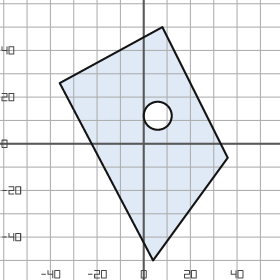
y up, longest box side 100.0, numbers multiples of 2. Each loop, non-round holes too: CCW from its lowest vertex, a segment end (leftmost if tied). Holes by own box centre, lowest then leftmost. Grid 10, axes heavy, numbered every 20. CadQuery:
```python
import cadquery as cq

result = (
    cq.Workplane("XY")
    .moveTo(4.0, -50.0)
    .lineTo(36.0, -6.0)
    .lineTo(8.0, 50.0)
    .lineTo(-36.0, 26.0)
    .close()
    .moveTo(6.0, 12.0)
    .circle(6.0)
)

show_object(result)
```